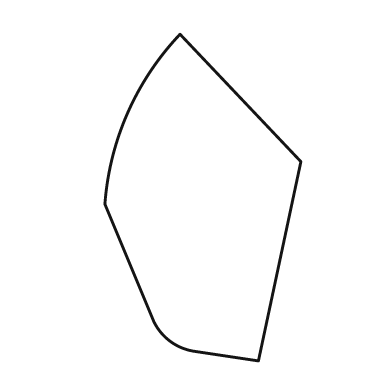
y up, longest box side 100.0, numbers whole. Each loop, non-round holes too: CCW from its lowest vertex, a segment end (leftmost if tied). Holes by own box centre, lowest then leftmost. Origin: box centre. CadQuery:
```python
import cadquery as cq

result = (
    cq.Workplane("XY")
    .moveTo(17.0, -50.0)
    .lineTo(30.0, 11.0)
    .lineTo(-7.0, 50.0)
    .threePointArc((-23.0, 26.0), (-30.0, -2.0))
    .lineTo(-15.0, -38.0)
    .threePointArc((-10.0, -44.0), (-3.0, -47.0))
    .close()
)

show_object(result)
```